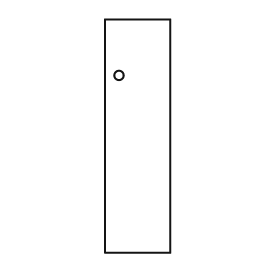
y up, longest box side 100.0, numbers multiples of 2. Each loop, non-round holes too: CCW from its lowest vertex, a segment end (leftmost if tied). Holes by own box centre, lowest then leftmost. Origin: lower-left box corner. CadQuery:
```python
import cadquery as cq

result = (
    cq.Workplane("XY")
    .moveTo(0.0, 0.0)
    .lineTo(28.0, 0.0)
    .lineTo(28.0, 100.0)
    .lineTo(0.0, 100.0)
    .close()
    .moveTo(6.0, 76.0)
    .circle(2.0)
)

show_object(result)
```